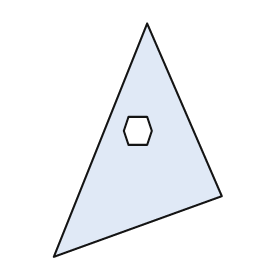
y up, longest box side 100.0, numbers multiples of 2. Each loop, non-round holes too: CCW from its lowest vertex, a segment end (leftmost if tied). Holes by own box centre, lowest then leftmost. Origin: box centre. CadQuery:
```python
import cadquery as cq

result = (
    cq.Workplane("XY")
    .moveTo(-36.0, -50.0)
    .lineTo(36.0, -24.0)
    .lineTo(4.0, 50.0)
    .close()
    .moveTo(-4.0, -2.0)
    .lineTo(4.0, -2.0)
    .lineTo(6.0, 4.0)
    .lineTo(4.0, 10.0)
    .lineTo(-4.0, 10.0)
    .lineTo(-6.0, 4.0)
    .close()
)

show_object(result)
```